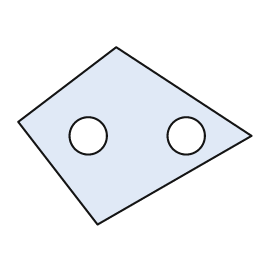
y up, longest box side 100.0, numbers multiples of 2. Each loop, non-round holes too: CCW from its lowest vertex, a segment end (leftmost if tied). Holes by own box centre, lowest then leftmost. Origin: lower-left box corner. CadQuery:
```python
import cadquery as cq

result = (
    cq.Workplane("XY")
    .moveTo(34.0, 0.0)
    .lineTo(100.0, 38.0)
    .lineTo(42.0, 76.0)
    .lineTo(0.0, 44.0)
    .close()
    .moveTo(30.0, 38.0)
    .circle(8.0)
    .moveTo(72.0, 38.0)
    .circle(8.0)
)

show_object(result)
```